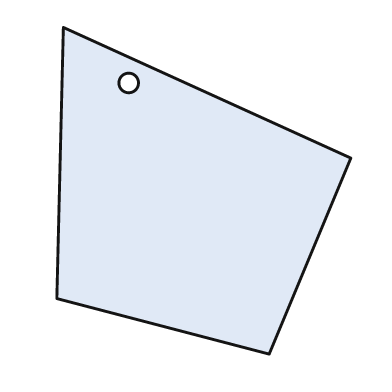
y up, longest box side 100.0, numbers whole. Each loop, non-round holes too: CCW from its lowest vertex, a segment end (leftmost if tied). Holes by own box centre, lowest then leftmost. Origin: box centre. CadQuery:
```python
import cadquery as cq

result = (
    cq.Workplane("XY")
    .moveTo(20.0, -50.0)
    .lineTo(45.0, 10.0)
    .lineTo(-43.0, 50.0)
    .lineTo(-45.0, -33.0)
    .close()
    .moveTo(-23.0, 33.0)
    .circle(3.0)
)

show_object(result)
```